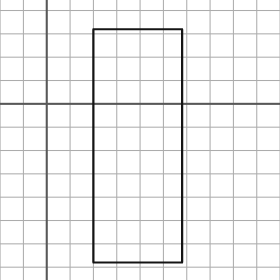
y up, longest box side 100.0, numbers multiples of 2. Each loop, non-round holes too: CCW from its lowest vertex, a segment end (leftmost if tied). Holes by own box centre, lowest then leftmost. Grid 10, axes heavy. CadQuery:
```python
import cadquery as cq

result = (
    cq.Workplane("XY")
    .moveTo(20.0, -68.0)
    .lineTo(58.0, -68.0)
    .lineTo(58.0, 32.0)
    .lineTo(20.0, 32.0)
    .close()
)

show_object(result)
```